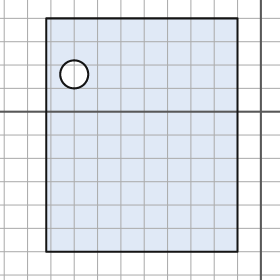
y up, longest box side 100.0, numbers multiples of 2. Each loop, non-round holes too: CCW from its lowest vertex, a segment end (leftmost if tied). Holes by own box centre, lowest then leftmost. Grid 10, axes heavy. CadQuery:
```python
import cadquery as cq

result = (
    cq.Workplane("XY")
    .moveTo(-92.0, -60.0)
    .lineTo(-10.0, -60.0)
    .lineTo(-10.0, 40.0)
    .lineTo(-92.0, 40.0)
    .close()
    .moveTo(-80.0, 16.0)
    .circle(6.0)
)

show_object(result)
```